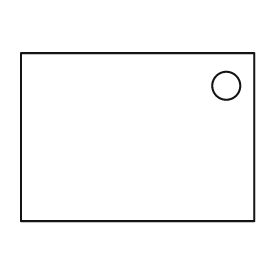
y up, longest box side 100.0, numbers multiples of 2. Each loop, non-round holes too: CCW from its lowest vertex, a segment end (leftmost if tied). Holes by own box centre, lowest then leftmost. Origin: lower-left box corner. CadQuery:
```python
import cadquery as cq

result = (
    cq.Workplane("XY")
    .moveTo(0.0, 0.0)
    .lineTo(100.0, 0.0)
    .lineTo(100.0, 72.0)
    .lineTo(0.0, 72.0)
    .close()
    .moveTo(88.0, 58.0)
    .circle(6.0)
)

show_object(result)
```